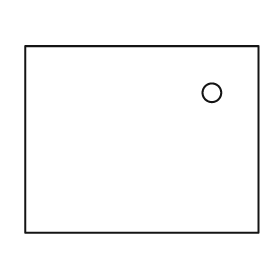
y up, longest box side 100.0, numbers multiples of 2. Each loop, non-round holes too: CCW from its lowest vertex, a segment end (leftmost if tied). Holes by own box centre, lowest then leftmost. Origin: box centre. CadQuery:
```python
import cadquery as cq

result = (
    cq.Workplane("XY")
    .moveTo(-50.0, -40.0)
    .lineTo(50.0, -40.0)
    .lineTo(50.0, 40.0)
    .lineTo(-50.0, 40.0)
    .close()
    .moveTo(30.0, 20.0)
    .circle(4.0)
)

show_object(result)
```